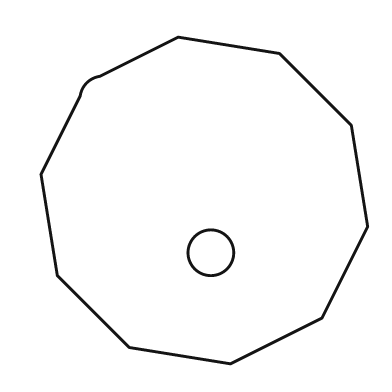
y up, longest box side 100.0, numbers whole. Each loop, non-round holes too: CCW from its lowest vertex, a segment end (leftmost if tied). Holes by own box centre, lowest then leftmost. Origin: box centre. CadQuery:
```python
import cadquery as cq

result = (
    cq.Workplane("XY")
    .moveTo(8.0, -50.0)
    .lineTo(36.0, -36.0)
    .lineTo(50.0, -8.0)
    .lineTo(45.0, 23.0)
    .lineTo(23.0, 45.0)
    .lineTo(-8.0, 50.0)
    .lineTo(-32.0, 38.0)
    .threePointArc((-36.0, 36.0), (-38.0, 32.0))
    .lineTo(-50.0, 8.0)
    .lineTo(-45.0, -23.0)
    .lineTo(-23.0, -45.0)
    .close()
    .moveTo(2.0, -16.0)
    .circle(7.0)
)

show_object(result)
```